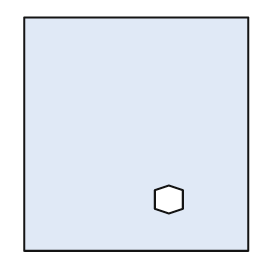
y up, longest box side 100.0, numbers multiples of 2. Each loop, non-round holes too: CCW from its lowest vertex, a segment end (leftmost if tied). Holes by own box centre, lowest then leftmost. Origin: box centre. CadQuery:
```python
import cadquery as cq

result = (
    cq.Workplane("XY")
    .moveTo(-48.0, -50.0)
    .lineTo(48.0, -50.0)
    .lineTo(48.0, 50.0)
    .lineTo(-48.0, 50.0)
    .close()
    .moveTo(14.0, -34.0)
    .lineTo(20.0, -32.0)
    .lineTo(20.0, -24.0)
    .lineTo(14.0, -22.0)
    .lineTo(8.0, -24.0)
    .lineTo(8.0, -32.0)
    .close()
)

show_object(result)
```